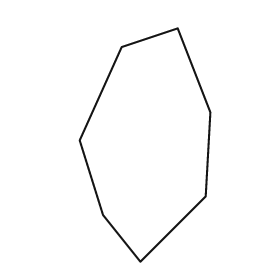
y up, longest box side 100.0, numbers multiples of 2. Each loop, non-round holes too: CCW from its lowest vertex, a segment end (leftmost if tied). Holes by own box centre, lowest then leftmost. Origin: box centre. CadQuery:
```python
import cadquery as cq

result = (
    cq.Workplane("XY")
    .moveTo(-2.0, -50.0)
    .lineTo(26.0, -22.0)
    .lineTo(28.0, 14.0)
    .lineTo(14.0, 50.0)
    .lineTo(-10.0, 42.0)
    .lineTo(-28.0, 2.0)
    .lineTo(-18.0, -30.0)
    .close()
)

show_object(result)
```